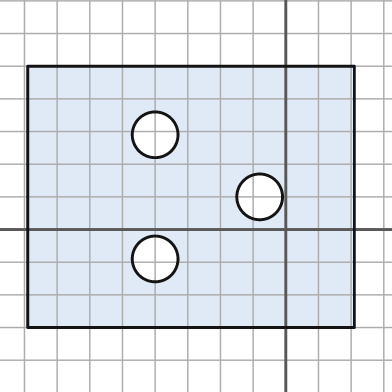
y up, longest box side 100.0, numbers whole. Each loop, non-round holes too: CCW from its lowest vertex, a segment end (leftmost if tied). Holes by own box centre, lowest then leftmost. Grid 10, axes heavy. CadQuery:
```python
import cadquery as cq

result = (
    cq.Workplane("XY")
    .moveTo(-79.0, -30.0)
    .lineTo(21.0, -30.0)
    .lineTo(21.0, 50.0)
    .lineTo(-79.0, 50.0)
    .close()
    .moveTo(-40.0, -9.0)
    .circle(7.0)
    .moveTo(-8.0, 10.0)
    .circle(7.0)
    .moveTo(-40.0, 29.0)
    .circle(7.0)
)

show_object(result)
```